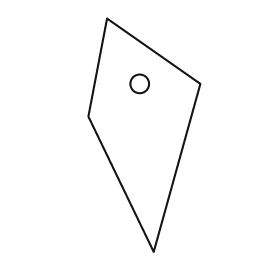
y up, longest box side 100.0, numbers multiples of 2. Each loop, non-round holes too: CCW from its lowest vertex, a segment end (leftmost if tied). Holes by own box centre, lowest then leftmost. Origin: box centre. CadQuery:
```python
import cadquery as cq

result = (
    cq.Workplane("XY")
    .moveTo(4.0, -50.0)
    .lineTo(24.0, 22.0)
    .lineTo(-16.0, 50.0)
    .lineTo(-24.0, 8.0)
    .close()
    .moveTo(-2.0, 22.0)
    .circle(4.0)
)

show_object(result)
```